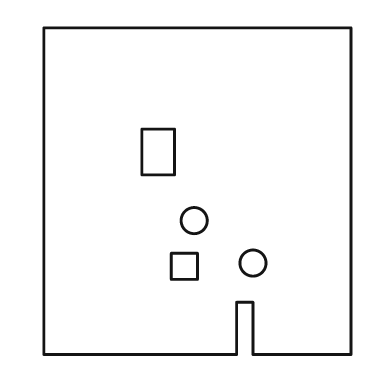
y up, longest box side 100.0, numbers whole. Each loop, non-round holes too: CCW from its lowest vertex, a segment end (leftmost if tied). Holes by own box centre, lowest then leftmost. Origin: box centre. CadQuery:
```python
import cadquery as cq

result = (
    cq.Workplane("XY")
    .moveTo(-47.0, -50.0)
    .lineTo(12.0, -50.0)
    .lineTo(12.0, -34.0)
    .lineTo(17.0, -34.0)
    .lineTo(17.0, -50.0)
    .lineTo(47.0, -50.0)
    .lineTo(47.0, 50.0)
    .lineTo(-47.0, 50.0)
    .close()
    .moveTo(-8.0, -27.0)
    .lineTo(0.0, -27.0)
    .lineTo(0.0, -19.0)
    .lineTo(-8.0, -19.0)
    .close()
    .moveTo(17.0, -22.0)
    .circle(4.0)
    .moveTo(-1.0, -9.0)
    .circle(4.0)
    .moveTo(-17.0, 5.0)
    .lineTo(-7.0, 5.0)
    .lineTo(-7.0, 19.0)
    .lineTo(-17.0, 19.0)
    .close()
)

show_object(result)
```